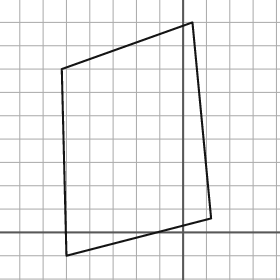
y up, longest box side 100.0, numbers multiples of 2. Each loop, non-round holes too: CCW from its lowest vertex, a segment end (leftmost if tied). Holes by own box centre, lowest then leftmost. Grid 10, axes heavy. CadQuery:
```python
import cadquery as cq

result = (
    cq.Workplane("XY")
    .moveTo(-50.0, -10.0)
    .lineTo(12.0, 6.0)
    .lineTo(4.0, 90.0)
    .lineTo(-52.0, 70.0)
    .close()
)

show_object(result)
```